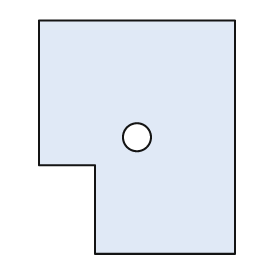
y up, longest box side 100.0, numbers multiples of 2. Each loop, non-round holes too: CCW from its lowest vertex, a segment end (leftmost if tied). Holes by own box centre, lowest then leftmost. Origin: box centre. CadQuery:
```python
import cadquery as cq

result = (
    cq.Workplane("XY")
    .moveTo(-18.0, -50.0)
    .lineTo(42.0, -50.0)
    .lineTo(42.0, 50.0)
    .lineTo(-42.0, 50.0)
    .lineTo(-42.0, -12.0)
    .lineTo(-18.0, -12.0)
    .close()
    .moveTo(0.0, 0.0)
    .circle(6.0)
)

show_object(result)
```